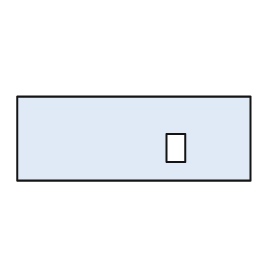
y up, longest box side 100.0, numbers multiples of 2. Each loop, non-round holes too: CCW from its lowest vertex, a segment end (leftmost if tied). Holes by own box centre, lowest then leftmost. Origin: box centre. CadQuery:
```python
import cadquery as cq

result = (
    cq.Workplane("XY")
    .moveTo(-50.0, -18.0)
    .lineTo(50.0, -18.0)
    .lineTo(50.0, 18.0)
    .lineTo(-50.0, 18.0)
    .close()
    .moveTo(14.0, -10.0)
    .lineTo(22.0, -10.0)
    .lineTo(22.0, 2.0)
    .lineTo(14.0, 2.0)
    .close()
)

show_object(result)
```